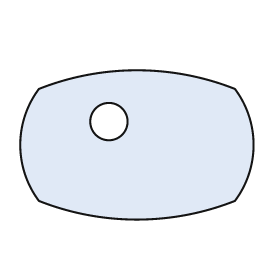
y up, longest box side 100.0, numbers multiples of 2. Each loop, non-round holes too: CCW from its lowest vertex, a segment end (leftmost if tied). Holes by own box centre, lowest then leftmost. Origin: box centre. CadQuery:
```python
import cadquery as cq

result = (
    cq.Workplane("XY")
    .moveTo(-42.0, -24.0)
    .threePointArc((0.0, -32.0), (42.0, -24.0))
    .threePointArc((50.0, 0.0), (42.0, 24.0))
    .threePointArc((0.0, 32.0), (-42.0, 24.0))
    .threePointArc((-50.0, 0.0), (-42.0, -24.0))
    .close()
    .moveTo(-12.0, 10.0)
    .circle(8.0)
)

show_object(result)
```